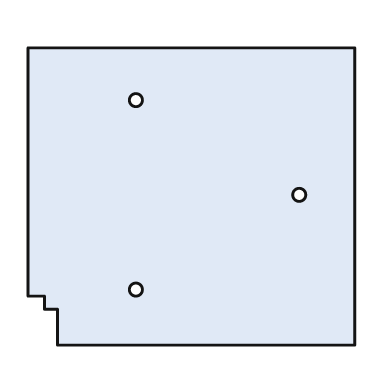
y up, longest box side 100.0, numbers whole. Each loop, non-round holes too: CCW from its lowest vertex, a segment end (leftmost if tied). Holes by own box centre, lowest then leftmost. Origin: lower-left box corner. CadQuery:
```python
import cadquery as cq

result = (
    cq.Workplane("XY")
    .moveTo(9.0, 0.0)
    .lineTo(100.0, 0.0)
    .lineTo(100.0, 91.0)
    .lineTo(0.0, 91.0)
    .lineTo(0.0, 15.0)
    .lineTo(5.0, 15.0)
    .lineTo(5.0, 11.0)
    .lineTo(9.0, 11.0)
    .close()
    .moveTo(33.0, 17.0)
    .circle(2.0)
    .moveTo(83.0, 46.0)
    .circle(2.0)
    .moveTo(33.0, 75.0)
    .circle(2.0)
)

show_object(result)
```